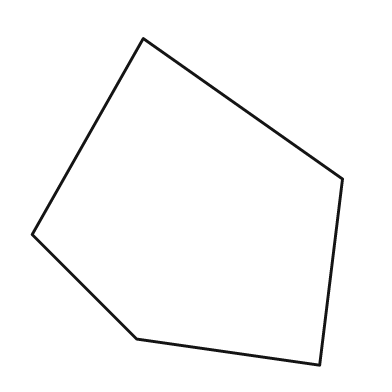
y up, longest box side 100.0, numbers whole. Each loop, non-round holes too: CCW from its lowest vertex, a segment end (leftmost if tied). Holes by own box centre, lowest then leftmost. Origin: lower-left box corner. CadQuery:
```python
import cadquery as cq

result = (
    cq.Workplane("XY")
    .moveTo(88.0, 0.0)
    .lineTo(95.0, 57.0)
    .lineTo(34.0, 100.0)
    .lineTo(0.0, 40.0)
    .lineTo(32.0, 8.0)
    .close()
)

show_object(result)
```